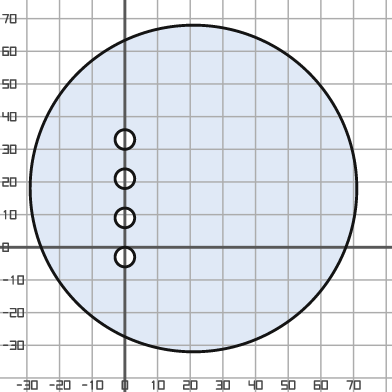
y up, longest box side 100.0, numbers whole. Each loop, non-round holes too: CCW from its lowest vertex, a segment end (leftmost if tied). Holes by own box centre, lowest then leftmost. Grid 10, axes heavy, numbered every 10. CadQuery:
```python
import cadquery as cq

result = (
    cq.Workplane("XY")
    .moveTo(21.0, 18.0)
    .circle(50.0)
    .moveTo(0.0, -3.0)
    .circle(3.0)
    .moveTo(0.0, 9.0)
    .circle(3.0)
    .moveTo(0.0, 21.0)
    .circle(3.0)
    .moveTo(0.0, 33.0)
    .circle(3.0)
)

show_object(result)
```